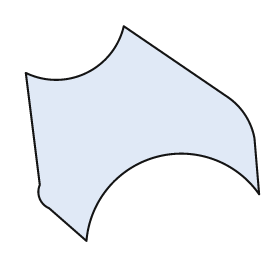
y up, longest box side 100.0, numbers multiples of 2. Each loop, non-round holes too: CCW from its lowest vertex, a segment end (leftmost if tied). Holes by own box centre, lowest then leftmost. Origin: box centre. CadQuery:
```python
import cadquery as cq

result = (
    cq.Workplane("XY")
    .moveTo(-24.0, -46.0)
    .threePointArc((6.0, -10.0), (50.0, -26.0))
    .lineTo(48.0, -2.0)
    .threePointArc((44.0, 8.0), (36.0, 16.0))
    .lineTo(-8.0, 46.0)
    .threePointArc((-24.0, 26.0), (-50.0, 26.0))
    .lineTo(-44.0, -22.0)
    .threePointArc((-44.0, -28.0), (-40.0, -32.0))
    .close()
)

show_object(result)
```